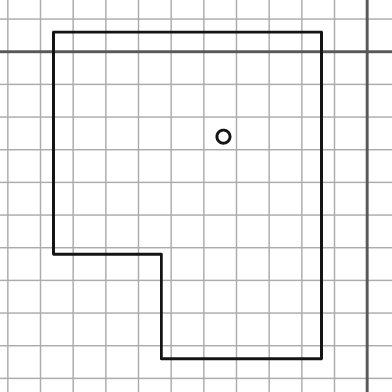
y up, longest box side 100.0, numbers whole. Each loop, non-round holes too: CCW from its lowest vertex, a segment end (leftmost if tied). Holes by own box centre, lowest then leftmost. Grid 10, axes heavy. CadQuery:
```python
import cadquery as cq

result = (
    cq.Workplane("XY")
    .moveTo(-63.0, -94.0)
    .lineTo(-14.0, -94.0)
    .lineTo(-14.0, 6.0)
    .lineTo(-96.0, 6.0)
    .lineTo(-96.0, -62.0)
    .lineTo(-63.0, -62.0)
    .close()
    .moveTo(-44.0, -26.0)
    .circle(2.0)
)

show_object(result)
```